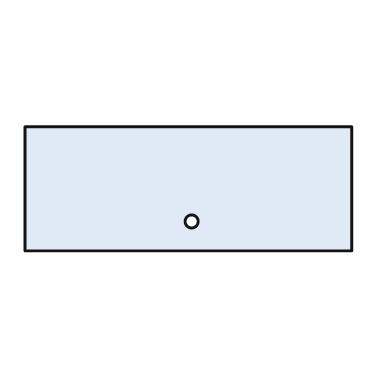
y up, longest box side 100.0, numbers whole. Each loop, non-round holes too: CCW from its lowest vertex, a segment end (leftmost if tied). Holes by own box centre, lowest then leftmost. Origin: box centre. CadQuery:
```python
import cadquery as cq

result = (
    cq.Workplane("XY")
    .moveTo(-50.0, -19.0)
    .lineTo(50.0, -19.0)
    .lineTo(50.0, 19.0)
    .lineTo(-50.0, 19.0)
    .close()
    .moveTo(1.0, -10.0)
    .circle(2.0)
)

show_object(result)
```